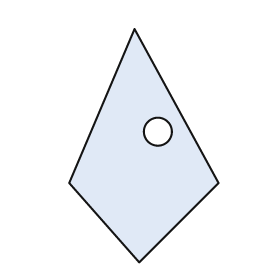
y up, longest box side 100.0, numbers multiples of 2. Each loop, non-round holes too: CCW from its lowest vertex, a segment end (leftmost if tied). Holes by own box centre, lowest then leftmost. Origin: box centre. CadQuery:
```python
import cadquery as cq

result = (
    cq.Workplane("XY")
    .moveTo(-2.0, -50.0)
    .lineTo(32.0, -16.0)
    .lineTo(-4.0, 50.0)
    .lineTo(-32.0, -16.0)
    .close()
    .moveTo(6.0, 6.0)
    .circle(6.0)
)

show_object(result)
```